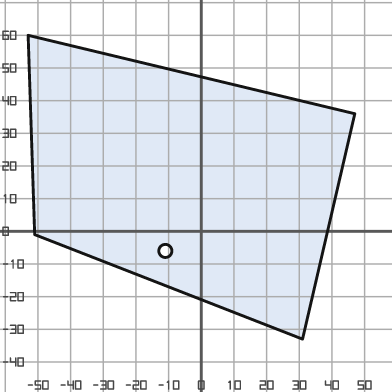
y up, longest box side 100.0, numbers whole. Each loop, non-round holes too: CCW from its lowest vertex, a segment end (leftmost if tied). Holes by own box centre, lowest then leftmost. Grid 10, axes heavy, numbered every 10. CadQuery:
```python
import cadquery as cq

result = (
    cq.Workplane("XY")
    .moveTo(31.0, -33.0)
    .lineTo(47.0, 36.0)
    .lineTo(-53.0, 60.0)
    .lineTo(-51.0, -1.0)
    .close()
    .moveTo(-11.0, -6.0)
    .circle(2.0)
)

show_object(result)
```